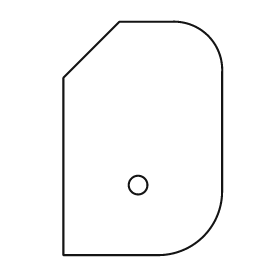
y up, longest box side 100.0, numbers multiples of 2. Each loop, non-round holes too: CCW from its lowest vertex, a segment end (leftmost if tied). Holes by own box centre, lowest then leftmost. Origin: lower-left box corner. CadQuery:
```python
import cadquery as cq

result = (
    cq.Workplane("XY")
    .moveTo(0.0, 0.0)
    .lineTo(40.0, 0.0)
    .threePointArc((60.0, 8.0), (68.0, 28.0))
    .lineTo(68.0, 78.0)
    .threePointArc((62.0, 94.0), (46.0, 100.0))
    .lineTo(24.0, 100.0)
    .lineTo(0.0, 76.0)
    .close()
    .moveTo(32.0, 30.0)
    .circle(4.0)
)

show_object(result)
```